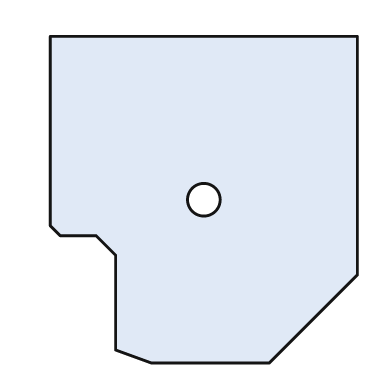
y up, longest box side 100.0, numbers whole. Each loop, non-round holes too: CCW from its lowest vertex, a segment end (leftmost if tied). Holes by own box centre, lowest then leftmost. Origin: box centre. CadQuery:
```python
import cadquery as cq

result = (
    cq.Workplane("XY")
    .moveTo(-16.0, -50.0)
    .lineTo(20.0, -50.0)
    .lineTo(47.0, -23.0)
    .lineTo(47.0, 50.0)
    .lineTo(-47.0, 50.0)
    .lineTo(-47.0, -8.0)
    .lineTo(-44.0, -11.0)
    .lineTo(-33.0, -11.0)
    .lineTo(-27.0, -17.0)
    .lineTo(-27.0, -46.0)
    .close()
    .moveTo(0.0, 0.0)
    .circle(5.0)
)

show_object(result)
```